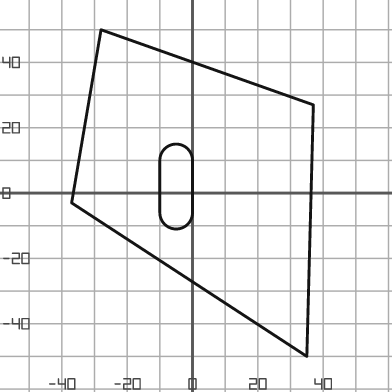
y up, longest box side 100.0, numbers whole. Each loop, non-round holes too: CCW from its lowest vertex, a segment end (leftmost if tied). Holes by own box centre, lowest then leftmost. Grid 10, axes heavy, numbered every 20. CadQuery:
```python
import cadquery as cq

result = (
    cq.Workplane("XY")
    .moveTo(35.0, -50.0)
    .lineTo(37.0, 27.0)
    .lineTo(-28.0, 50.0)
    .lineTo(-37.0, -3.0)
    .close()
    .moveTo(-10.0, -6.0)
    .threePointArc((-5.0, -11.0), (0.0, -6.0))
    .lineTo(0.0, 10.0)
    .threePointArc((-5.0, 15.0), (-10.0, 10.0))
    .close()
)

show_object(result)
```